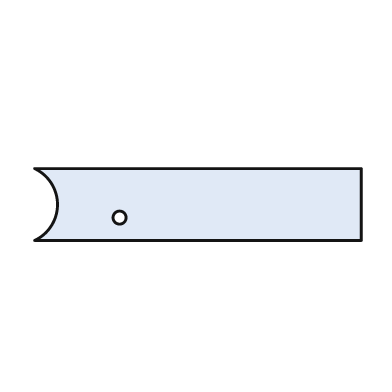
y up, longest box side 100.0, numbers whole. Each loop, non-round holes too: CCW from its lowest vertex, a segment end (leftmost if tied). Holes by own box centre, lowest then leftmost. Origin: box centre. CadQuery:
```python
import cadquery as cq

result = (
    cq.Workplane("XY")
    .moveTo(-50.0, -11.0)
    .lineTo(50.0, -11.0)
    .lineTo(50.0, 11.0)
    .lineTo(-50.0, 11.0)
    .threePointArc((-43.0, 0.0), (-50.0, -11.0))
    .close()
    .moveTo(-24.0, -4.0)
    .circle(2.0)
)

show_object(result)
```